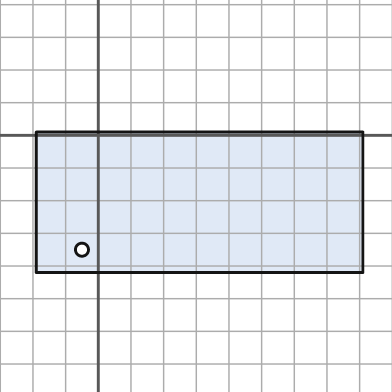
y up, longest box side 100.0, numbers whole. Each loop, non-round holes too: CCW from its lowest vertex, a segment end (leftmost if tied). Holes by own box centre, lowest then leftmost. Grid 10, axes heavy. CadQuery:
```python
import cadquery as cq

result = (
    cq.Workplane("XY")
    .moveTo(-19.0, -42.0)
    .lineTo(81.0, -42.0)
    .lineTo(81.0, 1.0)
    .lineTo(-19.0, 1.0)
    .close()
    .moveTo(-5.0, -35.0)
    .circle(2.0)
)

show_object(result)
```